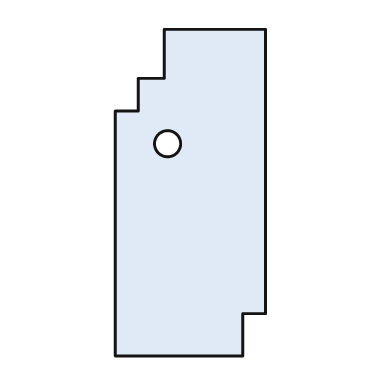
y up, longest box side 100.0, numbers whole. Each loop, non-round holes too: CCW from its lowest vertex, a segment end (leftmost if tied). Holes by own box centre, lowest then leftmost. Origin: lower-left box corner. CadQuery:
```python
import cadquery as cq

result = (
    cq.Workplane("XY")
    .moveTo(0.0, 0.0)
    .lineTo(39.0, 0.0)
    .lineTo(39.0, 13.0)
    .lineTo(46.0, 13.0)
    .lineTo(46.0, 100.0)
    .lineTo(15.0, 100.0)
    .lineTo(15.0, 85.0)
    .lineTo(7.0, 85.0)
    .lineTo(7.0, 75.0)
    .lineTo(0.0, 75.0)
    .close()
    .moveTo(16.0, 65.0)
    .circle(4.0)
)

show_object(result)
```